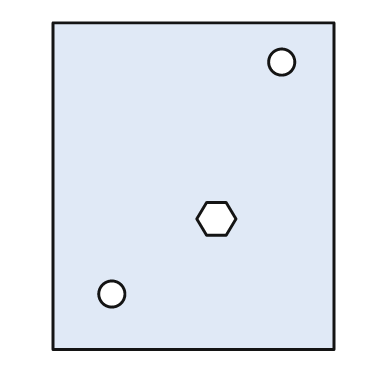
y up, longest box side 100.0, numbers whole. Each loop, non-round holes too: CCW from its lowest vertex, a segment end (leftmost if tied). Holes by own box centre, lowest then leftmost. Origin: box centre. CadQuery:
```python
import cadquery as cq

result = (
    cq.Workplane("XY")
    .moveTo(-43.0, -50.0)
    .lineTo(43.0, -50.0)
    .lineTo(43.0, 50.0)
    .lineTo(-43.0, 50.0)
    .close()
    .moveTo(-25.0, -33.0)
    .circle(4.0)
    .moveTo(4.0, -15.0)
    .lineTo(10.0, -15.0)
    .lineTo(13.0, -10.0)
    .lineTo(10.0, -5.0)
    .lineTo(4.0, -5.0)
    .lineTo(1.0, -10.0)
    .close()
    .moveTo(27.0, 38.0)
    .circle(4.0)
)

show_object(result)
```